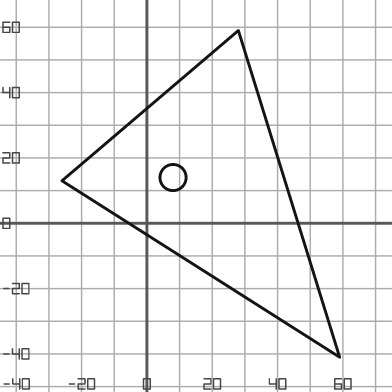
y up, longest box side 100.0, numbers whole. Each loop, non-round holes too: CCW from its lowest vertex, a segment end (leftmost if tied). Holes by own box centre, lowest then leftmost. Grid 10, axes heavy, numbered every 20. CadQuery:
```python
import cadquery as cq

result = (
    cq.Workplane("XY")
    .moveTo(59.0, -41.0)
    .lineTo(28.0, 59.0)
    .lineTo(-26.0, 13.0)
    .close()
    .moveTo(8.0, 14.0)
    .circle(4.0)
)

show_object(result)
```